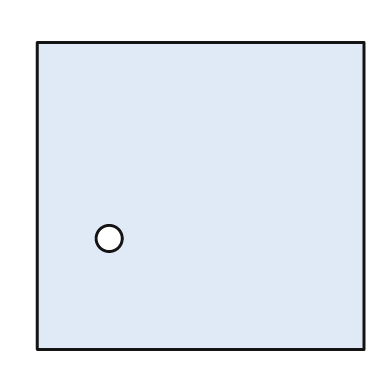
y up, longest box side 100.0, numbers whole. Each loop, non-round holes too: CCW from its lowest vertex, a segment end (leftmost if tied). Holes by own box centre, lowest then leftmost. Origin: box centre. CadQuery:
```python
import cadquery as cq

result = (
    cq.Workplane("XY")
    .moveTo(-50.0, -47.0)
    .lineTo(50.0, -47.0)
    .lineTo(50.0, 47.0)
    .lineTo(-50.0, 47.0)
    .close()
    .moveTo(-28.0, -13.0)
    .circle(4.0)
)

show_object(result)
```